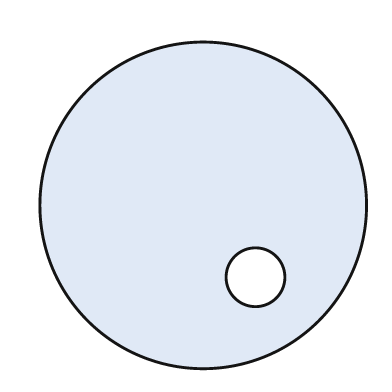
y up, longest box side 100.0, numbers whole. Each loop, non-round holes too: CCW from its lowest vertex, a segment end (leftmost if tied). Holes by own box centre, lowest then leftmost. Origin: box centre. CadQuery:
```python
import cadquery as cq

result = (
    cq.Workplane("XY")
    .moveTo(0.0, 0.0)
    .circle(50.0)
    .moveTo(16.0, -22.0)
    .circle(9.0)
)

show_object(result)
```